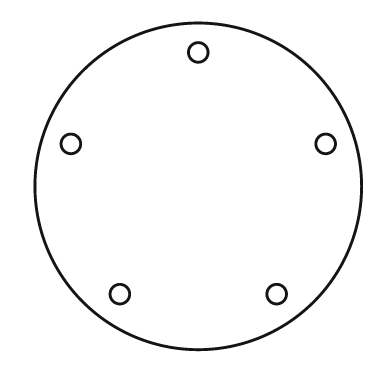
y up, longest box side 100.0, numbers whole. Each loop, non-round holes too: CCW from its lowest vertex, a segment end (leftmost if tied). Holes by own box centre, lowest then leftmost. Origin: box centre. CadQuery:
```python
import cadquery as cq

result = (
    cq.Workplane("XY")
    .moveTo(0.0, 0.0)
    .circle(50.0)
    .moveTo(-24.0, -33.0)
    .circle(3.0)
    .moveTo(24.0, -33.0)
    .circle(3.0)
    .moveTo(-39.0, 13.0)
    .circle(3.0)
    .moveTo(39.0, 13.0)
    .circle(3.0)
    .moveTo(0.0, 41.0)
    .circle(3.0)
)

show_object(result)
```